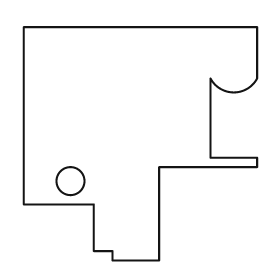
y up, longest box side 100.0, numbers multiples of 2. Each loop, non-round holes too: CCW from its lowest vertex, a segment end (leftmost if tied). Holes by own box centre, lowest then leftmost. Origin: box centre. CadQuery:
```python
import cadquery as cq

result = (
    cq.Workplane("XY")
    .moveTo(-12.0, -50.0)
    .lineTo(8.0, -50.0)
    .lineTo(8.0, -10.0)
    .lineTo(50.0, -10.0)
    .lineTo(50.0, -6.0)
    .lineTo(30.0, -6.0)
    .lineTo(30.0, 28.0)
    .threePointArc((40.0, 22.0), (50.0, 28.0))
    .lineTo(50.0, 50.0)
    .lineTo(-50.0, 50.0)
    .lineTo(-50.0, -26.0)
    .lineTo(-20.0, -26.0)
    .lineTo(-20.0, -46.0)
    .lineTo(-12.0, -46.0)
    .close()
    .moveTo(-30.0, -16.0)
    .circle(6.0)
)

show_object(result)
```